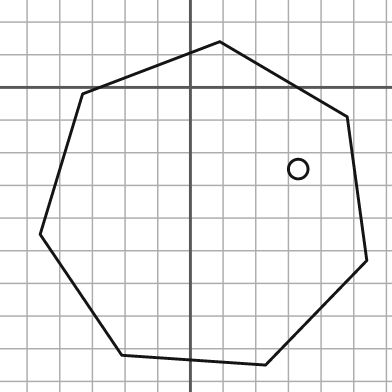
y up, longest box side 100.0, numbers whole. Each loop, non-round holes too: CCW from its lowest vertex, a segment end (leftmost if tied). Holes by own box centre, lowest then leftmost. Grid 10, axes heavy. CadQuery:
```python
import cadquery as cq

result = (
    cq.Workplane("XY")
    .moveTo(23.0, -85.0)
    .lineTo(54.0, -53.0)
    .lineTo(48.0, -9.0)
    .lineTo(9.0, 14.0)
    .lineTo(-33.0, -2.0)
    .lineTo(-46.0, -45.0)
    .lineTo(-21.0, -82.0)
    .close()
    .moveTo(33.0, -25.0)
    .circle(3.0)
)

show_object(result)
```